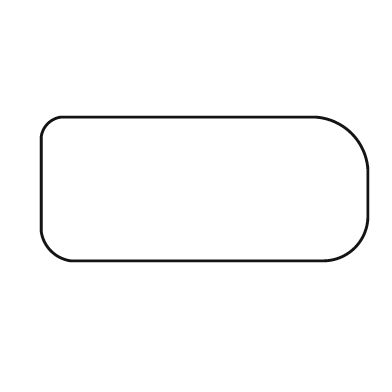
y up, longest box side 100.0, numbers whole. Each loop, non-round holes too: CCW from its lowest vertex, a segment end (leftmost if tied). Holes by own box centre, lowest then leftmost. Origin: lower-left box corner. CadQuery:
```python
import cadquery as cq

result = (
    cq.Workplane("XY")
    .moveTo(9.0, 0.0)
    .lineTo(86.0, 0.0)
    .threePointArc((96.0, 4.0), (100.0, 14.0))
    .lineTo(100.0, 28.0)
    .threePointArc((95.0, 39.0), (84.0, 44.0))
    .lineTo(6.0, 44.0)
    .threePointArc((2.0, 42.0), (0.0, 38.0))
    .lineTo(0.0, 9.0)
    .threePointArc((3.0, 3.0), (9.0, 0.0))
    .close()
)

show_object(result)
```